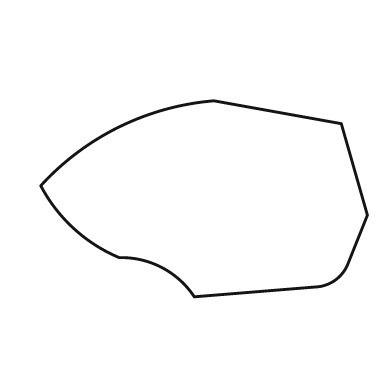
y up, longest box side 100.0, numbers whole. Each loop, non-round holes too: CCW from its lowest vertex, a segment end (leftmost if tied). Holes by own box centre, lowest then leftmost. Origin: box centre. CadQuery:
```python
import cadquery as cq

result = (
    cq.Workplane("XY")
    .moveTo(-3.0, -30.0)
    .lineTo(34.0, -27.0)
    .threePointArc((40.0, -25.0), (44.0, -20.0))
    .lineTo(50.0, -5.0)
    .lineTo(42.0, 23.0)
    .lineTo(3.0, 30.0)
    .threePointArc((-26.0, 22.0), (-50.0, 4.0))
    .threePointArc((-40.0, -9.0), (-26.0, -18.0))
    .threePointArc((-13.0, -21.0), (-3.0, -30.0))
    .close()
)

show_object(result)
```